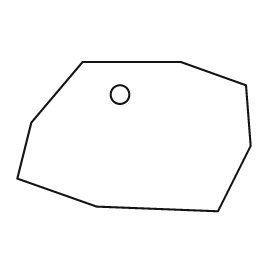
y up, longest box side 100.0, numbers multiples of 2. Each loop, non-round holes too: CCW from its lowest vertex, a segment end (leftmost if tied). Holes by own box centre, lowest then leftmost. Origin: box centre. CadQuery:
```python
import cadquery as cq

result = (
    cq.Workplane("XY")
    .moveTo(36.0, -32.0)
    .lineTo(50.0, -4.0)
    .lineTo(48.0, 22.0)
    .lineTo(20.0, 32.0)
    .lineTo(-22.0, 32.0)
    .lineTo(-44.0, 6.0)
    .lineTo(-50.0, -18.0)
    .lineTo(-16.0, -30.0)
    .close()
    .moveTo(-6.0, 18.0)
    .circle(4.0)
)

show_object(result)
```